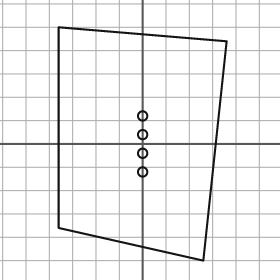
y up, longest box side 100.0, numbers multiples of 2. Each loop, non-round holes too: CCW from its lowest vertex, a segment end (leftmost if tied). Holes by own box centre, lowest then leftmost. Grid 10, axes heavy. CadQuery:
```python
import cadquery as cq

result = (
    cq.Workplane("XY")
    .moveTo(26.0, -50.0)
    .lineTo(36.0, 44.0)
    .lineTo(-36.0, 50.0)
    .lineTo(-36.0, -36.0)
    .close()
    .moveTo(0.0, -12.0)
    .circle(2.0)
    .moveTo(0.0, -4.0)
    .circle(2.0)
    .moveTo(0.0, 4.0)
    .circle(2.0)
    .moveTo(0.0, 12.0)
    .circle(2.0)
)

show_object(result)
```